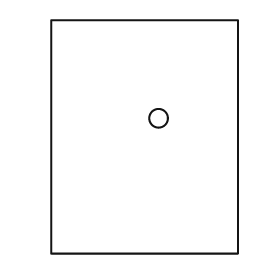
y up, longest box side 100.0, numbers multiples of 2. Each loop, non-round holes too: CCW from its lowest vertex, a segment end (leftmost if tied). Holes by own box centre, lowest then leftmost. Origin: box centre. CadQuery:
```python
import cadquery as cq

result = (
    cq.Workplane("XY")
    .moveTo(-40.0, -50.0)
    .lineTo(40.0, -50.0)
    .lineTo(40.0, 50.0)
    .lineTo(-40.0, 50.0)
    .close()
    .moveTo(6.0, 8.0)
    .circle(4.0)
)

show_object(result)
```